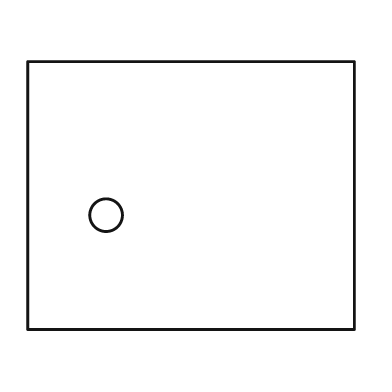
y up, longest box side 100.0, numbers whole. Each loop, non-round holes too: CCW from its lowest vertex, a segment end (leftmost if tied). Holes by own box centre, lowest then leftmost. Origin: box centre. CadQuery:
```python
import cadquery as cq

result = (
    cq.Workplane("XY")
    .moveTo(-50.0, -41.0)
    .lineTo(50.0, -41.0)
    .lineTo(50.0, 41.0)
    .lineTo(-50.0, 41.0)
    .close()
    .moveTo(-26.0, -6.0)
    .circle(5.0)
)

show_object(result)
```